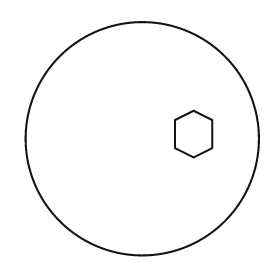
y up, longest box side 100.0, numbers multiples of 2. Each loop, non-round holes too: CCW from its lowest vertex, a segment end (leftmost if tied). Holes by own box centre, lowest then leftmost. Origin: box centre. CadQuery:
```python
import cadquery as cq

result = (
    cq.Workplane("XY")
    .moveTo(0.0, 0.0)
    .circle(50.0)
    .moveTo(22.0, -8.0)
    .lineTo(30.0, -4.0)
    .lineTo(30.0, 8.0)
    .lineTo(22.0, 12.0)
    .lineTo(14.0, 8.0)
    .lineTo(14.0, -4.0)
    .close()
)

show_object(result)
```